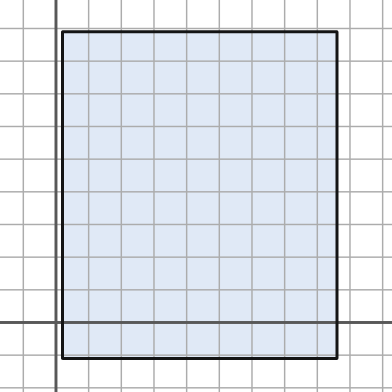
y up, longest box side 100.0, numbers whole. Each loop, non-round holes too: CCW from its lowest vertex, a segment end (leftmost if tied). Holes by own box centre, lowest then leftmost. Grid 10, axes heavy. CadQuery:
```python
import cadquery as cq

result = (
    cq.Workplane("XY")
    .moveTo(2.0, -11.0)
    .lineTo(86.0, -11.0)
    .lineTo(86.0, 89.0)
    .lineTo(2.0, 89.0)
    .close()
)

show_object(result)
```